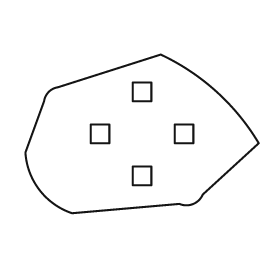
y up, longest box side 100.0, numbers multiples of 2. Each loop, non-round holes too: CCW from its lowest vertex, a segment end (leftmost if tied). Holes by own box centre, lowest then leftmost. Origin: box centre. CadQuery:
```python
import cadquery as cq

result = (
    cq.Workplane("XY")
    .moveTo(-30.0, -34.0)
    .lineTo(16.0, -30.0)
    .threePointArc((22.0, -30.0), (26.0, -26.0))
    .lineTo(50.0, -4.0)
    .threePointArc((32.0, 18.0), (8.0, 34.0))
    .lineTo(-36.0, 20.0)
    .threePointArc((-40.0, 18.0), (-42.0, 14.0))
    .lineTo(-50.0, -8.0)
    .threePointArc((-44.0, -24.0), (-30.0, -34.0))
    .close()
    .moveTo(-4.0, -22.0)
    .lineTo(4.0, -22.0)
    .lineTo(4.0, -14.0)
    .lineTo(-4.0, -14.0)
    .close()
    .moveTo(-22.0, -4.0)
    .lineTo(-14.0, -4.0)
    .lineTo(-14.0, 4.0)
    .lineTo(-22.0, 4.0)
    .close()
    .moveTo(14.0, -4.0)
    .lineTo(22.0, -4.0)
    .lineTo(22.0, 4.0)
    .lineTo(14.0, 4.0)
    .close()
    .moveTo(-4.0, 14.0)
    .lineTo(4.0, 14.0)
    .lineTo(4.0, 22.0)
    .lineTo(-4.0, 22.0)
    .close()
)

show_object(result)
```